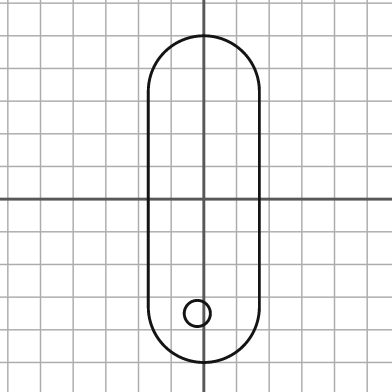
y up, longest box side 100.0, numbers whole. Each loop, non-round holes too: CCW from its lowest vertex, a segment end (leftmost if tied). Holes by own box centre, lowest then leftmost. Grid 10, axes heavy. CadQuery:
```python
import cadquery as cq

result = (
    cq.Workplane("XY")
    .moveTo(-17.0, -33.0)
    .threePointArc((0.0, -50.0), (17.0, -33.0))
    .lineTo(17.0, 33.0)
    .threePointArc((0.0, 50.0), (-17.0, 33.0))
    .close()
    .moveTo(-2.0, -35.0)
    .circle(4.0)
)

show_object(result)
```